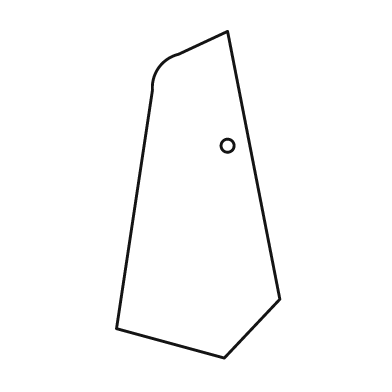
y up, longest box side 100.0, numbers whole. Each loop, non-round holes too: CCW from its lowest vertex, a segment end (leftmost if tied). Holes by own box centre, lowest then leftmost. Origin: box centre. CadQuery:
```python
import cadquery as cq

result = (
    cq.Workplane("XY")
    .moveTo(8.0, -50.0)
    .lineTo(25.0, -32.0)
    .lineTo(9.0, 50.0)
    .lineTo(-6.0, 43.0)
    .threePointArc((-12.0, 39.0), (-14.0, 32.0))
    .lineTo(-25.0, -41.0)
    .close()
    .moveTo(9.0, 15.0)
    .circle(2.0)
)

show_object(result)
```